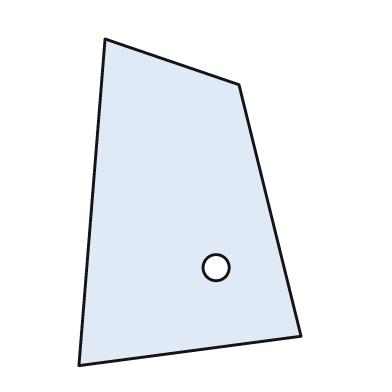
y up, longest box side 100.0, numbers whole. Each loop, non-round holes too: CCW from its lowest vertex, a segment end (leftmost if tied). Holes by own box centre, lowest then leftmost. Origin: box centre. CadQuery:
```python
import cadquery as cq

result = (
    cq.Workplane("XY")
    .moveTo(-34.0, -50.0)
    .lineTo(34.0, -41.0)
    .lineTo(15.0, 36.0)
    .lineTo(-26.0, 50.0)
    .close()
    .moveTo(8.0, -20.0)
    .circle(4.0)
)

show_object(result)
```